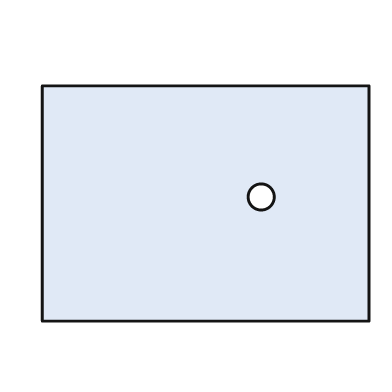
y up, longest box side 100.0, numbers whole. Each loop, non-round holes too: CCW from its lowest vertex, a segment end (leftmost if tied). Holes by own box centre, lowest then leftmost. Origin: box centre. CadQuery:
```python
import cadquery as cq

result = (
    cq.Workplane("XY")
    .moveTo(-50.0, -36.0)
    .lineTo(50.0, -36.0)
    .lineTo(50.0, 36.0)
    .lineTo(-50.0, 36.0)
    .close()
    .moveTo(17.0, 2.0)
    .circle(4.0)
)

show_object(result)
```